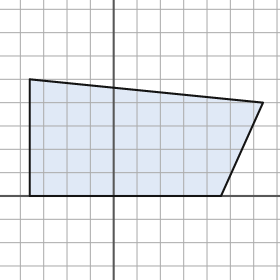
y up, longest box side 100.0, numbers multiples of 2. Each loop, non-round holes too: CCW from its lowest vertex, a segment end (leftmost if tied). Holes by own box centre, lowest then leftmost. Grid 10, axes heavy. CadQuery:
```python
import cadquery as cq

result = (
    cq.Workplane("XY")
    .moveTo(-36.0, 0.0)
    .lineTo(46.0, 0.0)
    .lineTo(64.0, 40.0)
    .lineTo(-36.0, 50.0)
    .close()
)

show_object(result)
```